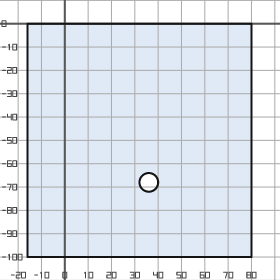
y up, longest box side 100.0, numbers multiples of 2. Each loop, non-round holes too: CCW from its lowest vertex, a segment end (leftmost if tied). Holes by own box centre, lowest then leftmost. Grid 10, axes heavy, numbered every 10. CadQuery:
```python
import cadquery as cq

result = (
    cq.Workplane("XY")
    .moveTo(-16.0, -100.0)
    .lineTo(80.0, -100.0)
    .lineTo(80.0, 0.0)
    .lineTo(-16.0, 0.0)
    .close()
    .moveTo(36.0, -68.0)
    .circle(4.0)
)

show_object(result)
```